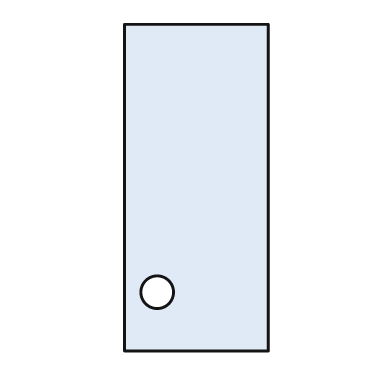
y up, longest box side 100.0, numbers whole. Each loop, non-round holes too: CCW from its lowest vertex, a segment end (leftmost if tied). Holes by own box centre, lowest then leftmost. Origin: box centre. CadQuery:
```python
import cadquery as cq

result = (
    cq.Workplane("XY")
    .moveTo(-22.0, -50.0)
    .lineTo(22.0, -50.0)
    .lineTo(22.0, 50.0)
    .lineTo(-22.0, 50.0)
    .close()
    .moveTo(-12.0, -32.0)
    .circle(5.0)
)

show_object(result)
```